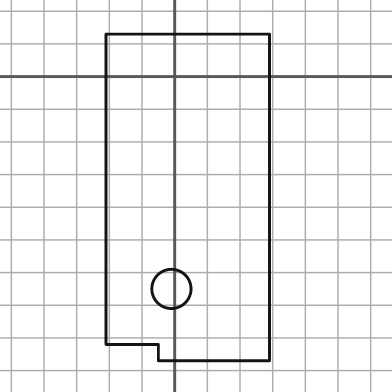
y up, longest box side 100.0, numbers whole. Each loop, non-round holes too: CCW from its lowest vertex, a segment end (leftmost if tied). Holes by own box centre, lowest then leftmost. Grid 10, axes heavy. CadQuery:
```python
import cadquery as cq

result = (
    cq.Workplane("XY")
    .moveTo(-5.0, -87.0)
    .lineTo(29.0, -87.0)
    .lineTo(29.0, 13.0)
    .lineTo(-21.0, 13.0)
    .lineTo(-21.0, -82.0)
    .lineTo(-5.0, -82.0)
    .close()
    .moveTo(-1.0, -65.0)
    .circle(6.0)
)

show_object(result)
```